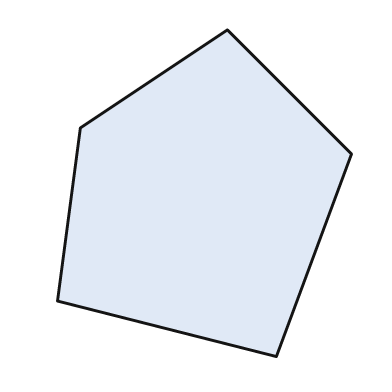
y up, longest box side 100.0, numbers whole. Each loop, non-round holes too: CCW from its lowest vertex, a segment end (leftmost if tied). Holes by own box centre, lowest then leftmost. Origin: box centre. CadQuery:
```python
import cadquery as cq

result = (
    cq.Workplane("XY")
    .moveTo(22.0, -50.0)
    .lineTo(45.0, 12.0)
    .lineTo(7.0, 50.0)
    .lineTo(-38.0, 20.0)
    .lineTo(-45.0, -33.0)
    .close()
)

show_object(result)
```